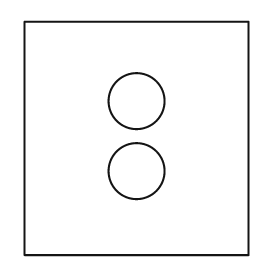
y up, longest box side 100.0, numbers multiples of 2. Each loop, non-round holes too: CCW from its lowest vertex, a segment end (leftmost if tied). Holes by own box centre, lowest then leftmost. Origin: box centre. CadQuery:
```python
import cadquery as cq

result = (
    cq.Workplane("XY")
    .moveTo(-48.0, -50.0)
    .lineTo(48.0, -50.0)
    .lineTo(48.0, 50.0)
    .lineTo(-48.0, 50.0)
    .close()
    .moveTo(0.0, -14.0)
    .circle(12.0)
    .moveTo(0.0, 16.0)
    .circle(12.0)
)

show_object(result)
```